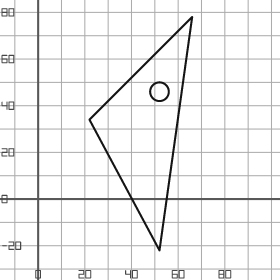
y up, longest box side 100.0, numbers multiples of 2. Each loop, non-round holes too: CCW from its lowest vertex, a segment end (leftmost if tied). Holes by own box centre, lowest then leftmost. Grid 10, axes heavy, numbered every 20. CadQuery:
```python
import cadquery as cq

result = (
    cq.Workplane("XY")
    .moveTo(52.0, -22.0)
    .lineTo(66.0, 78.0)
    .lineTo(22.0, 34.0)
    .close()
    .moveTo(52.0, 46.0)
    .circle(4.0)
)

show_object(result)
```